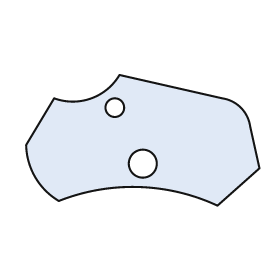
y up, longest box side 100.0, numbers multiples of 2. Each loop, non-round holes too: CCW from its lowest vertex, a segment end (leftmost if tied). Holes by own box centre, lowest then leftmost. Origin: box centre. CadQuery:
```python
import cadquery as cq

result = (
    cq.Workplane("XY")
    .moveTo(32.0, -28.0)
    .lineTo(50.0, -12.0)
    .lineTo(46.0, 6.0)
    .threePointArc((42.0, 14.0), (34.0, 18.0))
    .lineTo(-10.0, 28.0)
    .threePointArc((-22.0, 18.0), (-38.0, 18.0))
    .lineTo(-50.0, -2.0)
    .threePointArc((-46.0, -16.0), (-36.0, -26.0))
    .threePointArc((-2.0, -20.0), (32.0, -28.0))
    .close()
    .moveTo(0.0, -10.0)
    .circle(6.0)
    .moveTo(-12.0, 14.0)
    .circle(4.0)
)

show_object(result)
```